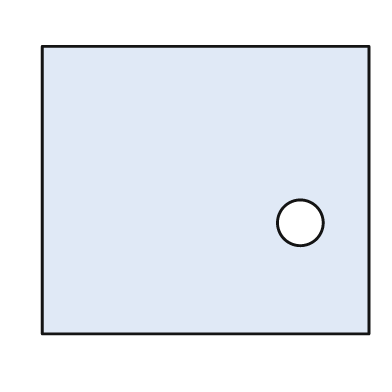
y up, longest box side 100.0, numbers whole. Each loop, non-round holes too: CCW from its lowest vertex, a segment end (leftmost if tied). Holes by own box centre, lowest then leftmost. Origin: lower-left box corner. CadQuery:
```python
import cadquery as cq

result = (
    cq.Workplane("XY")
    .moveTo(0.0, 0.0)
    .lineTo(100.0, 0.0)
    .lineTo(100.0, 88.0)
    .lineTo(0.0, 88.0)
    .close()
    .moveTo(79.0, 34.0)
    .circle(7.0)
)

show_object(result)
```